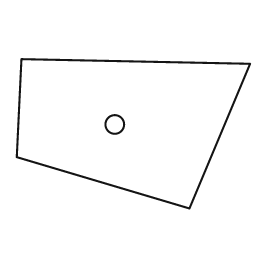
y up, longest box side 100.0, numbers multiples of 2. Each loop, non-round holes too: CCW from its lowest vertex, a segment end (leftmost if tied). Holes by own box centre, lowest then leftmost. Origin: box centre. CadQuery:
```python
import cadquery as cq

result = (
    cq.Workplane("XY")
    .moveTo(24.0, -32.0)
    .lineTo(50.0, 30.0)
    .lineTo(-48.0, 32.0)
    .lineTo(-50.0, -10.0)
    .close()
    .moveTo(-8.0, 4.0)
    .circle(4.0)
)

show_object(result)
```